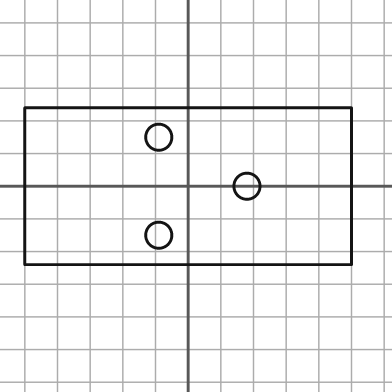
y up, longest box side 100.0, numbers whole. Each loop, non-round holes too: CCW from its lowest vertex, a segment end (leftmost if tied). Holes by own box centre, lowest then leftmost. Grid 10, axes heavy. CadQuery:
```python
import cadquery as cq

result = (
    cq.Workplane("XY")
    .moveTo(-50.0, -24.0)
    .lineTo(50.0, -24.0)
    .lineTo(50.0, 24.0)
    .lineTo(-50.0, 24.0)
    .close()
    .moveTo(-9.0, -15.0)
    .circle(4.0)
    .moveTo(18.0, 0.0)
    .circle(4.0)
    .moveTo(-9.0, 15.0)
    .circle(4.0)
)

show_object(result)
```